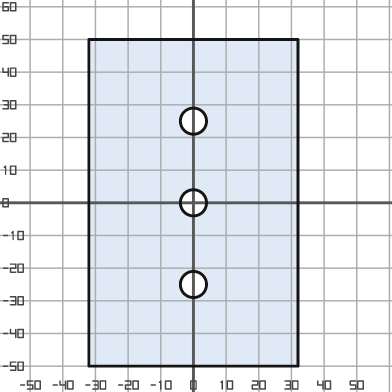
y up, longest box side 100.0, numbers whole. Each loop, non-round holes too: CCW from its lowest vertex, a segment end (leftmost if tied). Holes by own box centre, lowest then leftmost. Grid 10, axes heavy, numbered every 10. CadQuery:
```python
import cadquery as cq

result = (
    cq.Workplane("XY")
    .moveTo(-32.0, -50.0)
    .lineTo(32.0, -50.0)
    .lineTo(32.0, 50.0)
    .lineTo(-32.0, 50.0)
    .close()
    .moveTo(0.0, -25.0)
    .circle(4.0)
    .moveTo(0.0, 0.0)
    .circle(4.0)
    .moveTo(0.0, 25.0)
    .circle(4.0)
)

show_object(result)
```